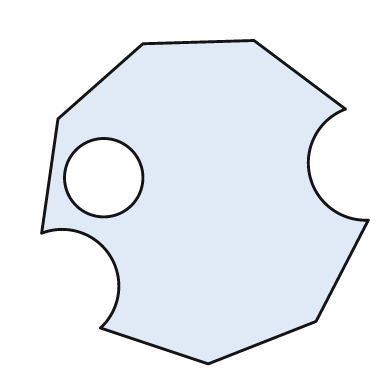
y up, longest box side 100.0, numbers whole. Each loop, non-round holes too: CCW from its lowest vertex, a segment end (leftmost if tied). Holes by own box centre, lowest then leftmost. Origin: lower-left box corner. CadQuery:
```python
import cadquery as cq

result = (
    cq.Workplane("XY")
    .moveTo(51.0, 0.0)
    .lineTo(84.0, 13.0)
    .lineTo(100.0, 44.0)
    .threePointArc((82.0, 58.0), (93.0, 78.0))
    .lineTo(65.0, 99.0)
    .lineTo(31.0, 98.0)
    .lineTo(5.0, 75.0)
    .lineTo(0.0, 40.0)
    .threePointArc((21.0, 33.0), (18.0, 11.0))
    .close()
    .moveTo(19.0, 57.0)
    .circle(12.0)
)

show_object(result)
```